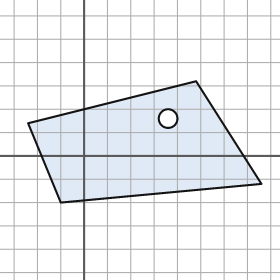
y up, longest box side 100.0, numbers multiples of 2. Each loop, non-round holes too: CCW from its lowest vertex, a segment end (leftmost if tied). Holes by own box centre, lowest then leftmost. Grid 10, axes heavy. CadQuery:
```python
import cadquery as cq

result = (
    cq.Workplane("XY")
    .moveTo(-10.0, -20.0)
    .lineTo(76.0, -12.0)
    .lineTo(48.0, 32.0)
    .lineTo(-24.0, 14.0)
    .close()
    .moveTo(36.0, 16.0)
    .circle(4.0)
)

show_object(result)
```